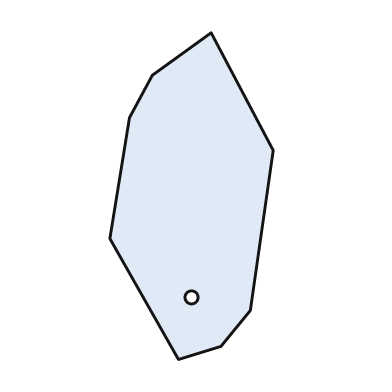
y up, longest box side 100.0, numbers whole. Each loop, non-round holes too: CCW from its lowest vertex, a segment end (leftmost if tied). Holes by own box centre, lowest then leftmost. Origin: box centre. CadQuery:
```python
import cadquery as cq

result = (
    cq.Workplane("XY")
    .moveTo(-4.0, -50.0)
    .lineTo(9.0, -46.0)
    .lineTo(18.0, -35.0)
    .lineTo(25.0, 14.0)
    .lineTo(6.0, 50.0)
    .lineTo(-12.0, 37.0)
    .lineTo(-19.0, 24.0)
    .lineTo(-25.0, -13.0)
    .close()
    .moveTo(0.0, -31.0)
    .circle(2.0)
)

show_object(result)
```